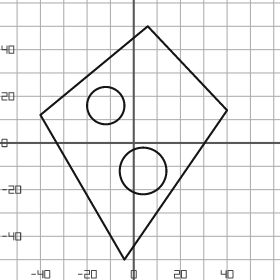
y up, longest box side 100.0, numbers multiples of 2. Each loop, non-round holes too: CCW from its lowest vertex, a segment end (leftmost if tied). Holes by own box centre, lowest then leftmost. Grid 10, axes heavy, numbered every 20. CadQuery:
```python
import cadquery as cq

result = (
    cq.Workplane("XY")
    .moveTo(-4.0, -50.0)
    .lineTo(40.0, 14.0)
    .lineTo(6.0, 50.0)
    .lineTo(-40.0, 12.0)
    .close()
    .moveTo(4.0, -12.0)
    .circle(10.0)
    .moveTo(-12.0, 16.0)
    .circle(8.0)
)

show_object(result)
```